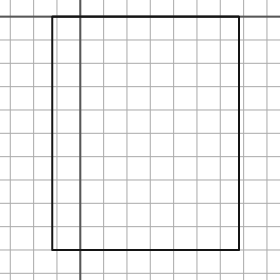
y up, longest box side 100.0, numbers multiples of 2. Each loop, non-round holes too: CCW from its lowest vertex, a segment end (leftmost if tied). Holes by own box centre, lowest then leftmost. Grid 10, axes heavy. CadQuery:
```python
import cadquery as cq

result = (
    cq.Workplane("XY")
    .moveTo(-12.0, -100.0)
    .lineTo(68.0, -100.0)
    .lineTo(68.0, 0.0)
    .lineTo(-12.0, 0.0)
    .close()
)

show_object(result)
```